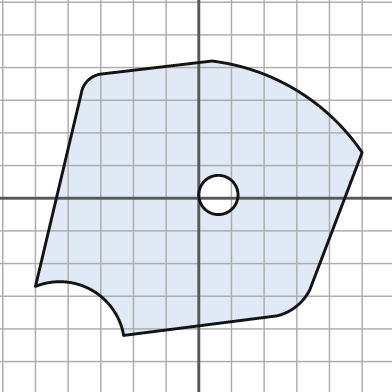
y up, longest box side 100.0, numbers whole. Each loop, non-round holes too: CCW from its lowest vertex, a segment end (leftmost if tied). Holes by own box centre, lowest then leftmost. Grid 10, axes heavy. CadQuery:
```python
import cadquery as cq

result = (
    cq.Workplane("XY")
    .moveTo(-23.0, -42.0)
    .lineTo(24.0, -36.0)
    .threePointArc((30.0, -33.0), (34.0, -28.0))
    .lineTo(50.0, 14.0)
    .threePointArc((30.0, 33.0), (4.0, 42.0))
    .lineTo(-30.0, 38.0)
    .threePointArc((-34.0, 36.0), (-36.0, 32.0))
    .lineTo(-50.0, -27.0)
    .threePointArc((-33.0, -28.0), (-23.0, -42.0))
    .close()
    .moveTo(6.0, 1.0)
    .circle(6.0)
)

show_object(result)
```